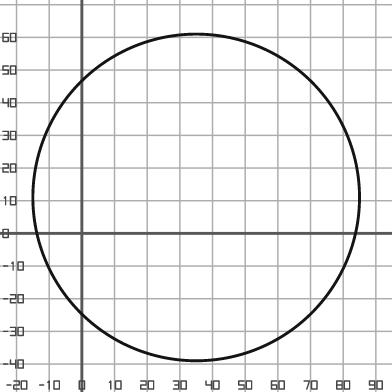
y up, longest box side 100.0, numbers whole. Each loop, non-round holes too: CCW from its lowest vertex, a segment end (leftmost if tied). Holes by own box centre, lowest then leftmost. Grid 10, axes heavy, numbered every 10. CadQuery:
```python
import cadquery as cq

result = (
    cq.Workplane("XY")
    .moveTo(35.0, 11.0)
    .circle(50.0)
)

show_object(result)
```